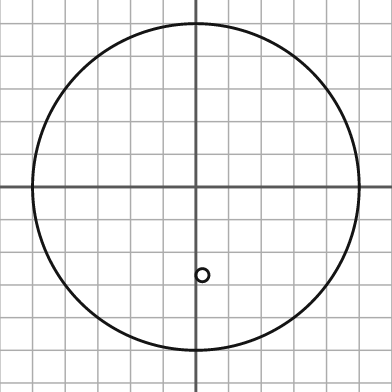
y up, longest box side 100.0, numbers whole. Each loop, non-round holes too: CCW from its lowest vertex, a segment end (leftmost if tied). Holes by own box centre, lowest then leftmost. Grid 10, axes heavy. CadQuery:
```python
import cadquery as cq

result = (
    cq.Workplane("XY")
    .moveTo(0.0, 0.0)
    .circle(50.0)
    .moveTo(2.0, -27.0)
    .circle(2.0)
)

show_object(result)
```